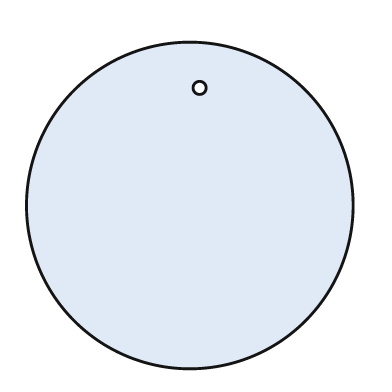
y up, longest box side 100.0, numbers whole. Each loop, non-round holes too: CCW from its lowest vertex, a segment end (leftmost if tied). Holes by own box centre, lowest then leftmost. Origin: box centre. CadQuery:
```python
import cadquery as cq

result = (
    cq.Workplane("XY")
    .moveTo(0.0, 0.0)
    .circle(50.0)
    .moveTo(3.0, 36.0)
    .circle(2.0)
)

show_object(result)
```